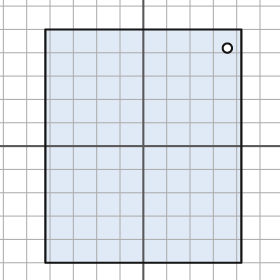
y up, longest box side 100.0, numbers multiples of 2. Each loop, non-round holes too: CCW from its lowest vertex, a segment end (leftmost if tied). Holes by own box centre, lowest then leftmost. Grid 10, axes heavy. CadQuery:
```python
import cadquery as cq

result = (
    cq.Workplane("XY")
    .moveTo(-42.0, -50.0)
    .lineTo(42.0, -50.0)
    .lineTo(42.0, 50.0)
    .lineTo(-42.0, 50.0)
    .close()
    .moveTo(36.0, 42.0)
    .circle(2.0)
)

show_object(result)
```